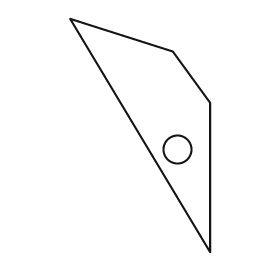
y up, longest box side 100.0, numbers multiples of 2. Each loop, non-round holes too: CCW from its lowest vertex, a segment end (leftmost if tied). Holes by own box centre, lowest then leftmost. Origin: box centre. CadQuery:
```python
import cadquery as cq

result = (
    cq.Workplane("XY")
    .moveTo(30.0, -50.0)
    .lineTo(30.0, 14.0)
    .lineTo(14.0, 36.0)
    .lineTo(-30.0, 50.0)
    .close()
    .moveTo(16.0, -6.0)
    .circle(6.0)
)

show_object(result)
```